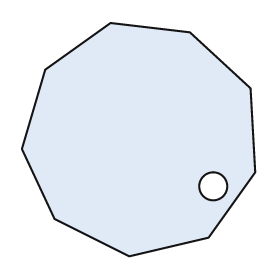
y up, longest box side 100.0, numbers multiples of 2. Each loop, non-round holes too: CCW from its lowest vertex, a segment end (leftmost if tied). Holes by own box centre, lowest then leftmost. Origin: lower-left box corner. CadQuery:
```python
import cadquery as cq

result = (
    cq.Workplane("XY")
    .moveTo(46.0, 0.0)
    .lineTo(80.0, 8.0)
    .lineTo(100.0, 36.0)
    .lineTo(98.0, 72.0)
    .lineTo(72.0, 96.0)
    .lineTo(38.0, 100.0)
    .lineTo(10.0, 80.0)
    .lineTo(0.0, 46.0)
    .lineTo(14.0, 16.0)
    .close()
    .moveTo(82.0, 30.0)
    .circle(6.0)
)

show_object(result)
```